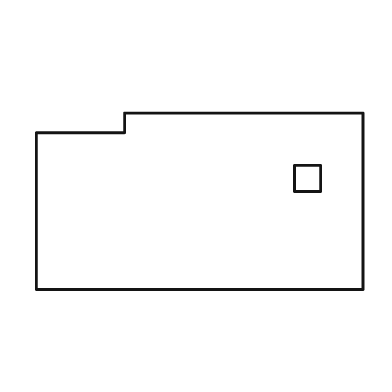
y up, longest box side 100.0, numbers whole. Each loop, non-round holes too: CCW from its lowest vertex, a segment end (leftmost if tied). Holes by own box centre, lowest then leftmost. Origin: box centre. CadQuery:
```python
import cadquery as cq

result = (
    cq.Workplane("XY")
    .moveTo(-50.0, -27.0)
    .lineTo(50.0, -27.0)
    .lineTo(50.0, 27.0)
    .lineTo(-23.0, 27.0)
    .lineTo(-23.0, 21.0)
    .lineTo(-50.0, 21.0)
    .close()
    .moveTo(29.0, 3.0)
    .lineTo(37.0, 3.0)
    .lineTo(37.0, 11.0)
    .lineTo(29.0, 11.0)
    .close()
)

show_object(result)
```